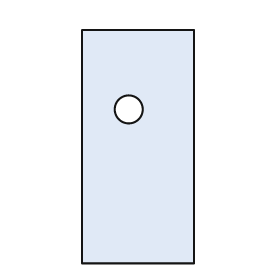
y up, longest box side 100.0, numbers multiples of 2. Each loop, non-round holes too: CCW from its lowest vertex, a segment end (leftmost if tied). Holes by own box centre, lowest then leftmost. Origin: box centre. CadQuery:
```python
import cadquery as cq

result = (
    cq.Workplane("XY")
    .moveTo(-24.0, -50.0)
    .lineTo(24.0, -50.0)
    .lineTo(24.0, 50.0)
    .lineTo(-24.0, 50.0)
    .close()
    .moveTo(-4.0, 16.0)
    .circle(6.0)
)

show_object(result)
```